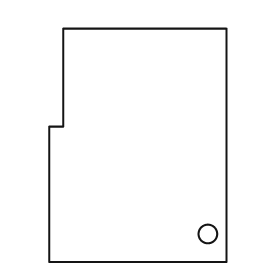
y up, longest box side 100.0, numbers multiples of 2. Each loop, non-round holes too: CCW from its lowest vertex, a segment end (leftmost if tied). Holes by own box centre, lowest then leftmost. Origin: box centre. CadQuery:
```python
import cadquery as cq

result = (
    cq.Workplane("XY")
    .moveTo(-38.0, -50.0)
    .lineTo(38.0, -50.0)
    .lineTo(38.0, 50.0)
    .lineTo(-32.0, 50.0)
    .lineTo(-32.0, 8.0)
    .lineTo(-38.0, 8.0)
    .close()
    .moveTo(30.0, -38.0)
    .circle(4.0)
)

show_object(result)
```